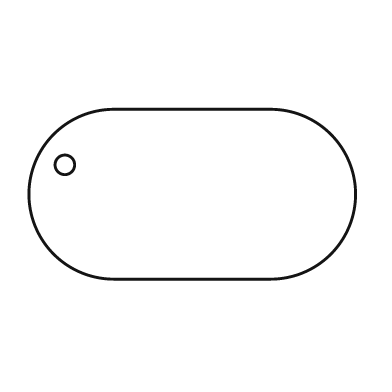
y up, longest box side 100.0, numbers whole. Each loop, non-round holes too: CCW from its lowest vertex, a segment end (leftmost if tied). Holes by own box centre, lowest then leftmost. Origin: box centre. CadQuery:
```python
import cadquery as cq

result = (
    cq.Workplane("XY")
    .moveTo(-24.0, -26.0)
    .lineTo(24.0, -26.0)
    .threePointArc((50.0, 0.0), (24.0, 26.0))
    .lineTo(-24.0, 26.0)
    .threePointArc((-50.0, 0.0), (-24.0, -26.0))
    .close()
    .moveTo(-39.0, 9.0)
    .circle(3.0)
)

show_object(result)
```